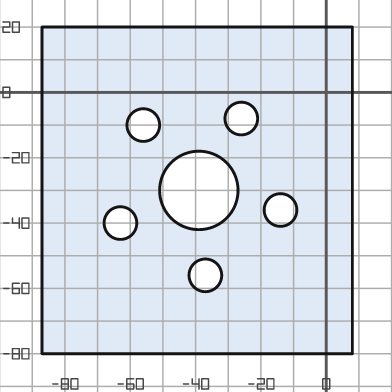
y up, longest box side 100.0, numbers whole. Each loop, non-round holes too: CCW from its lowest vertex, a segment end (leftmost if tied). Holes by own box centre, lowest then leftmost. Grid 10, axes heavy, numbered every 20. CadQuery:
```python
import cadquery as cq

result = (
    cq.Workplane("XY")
    .moveTo(-87.0, -80.0)
    .lineTo(8.0, -80.0)
    .lineTo(8.0, 20.0)
    .lineTo(-87.0, 20.0)
    .close()
    .moveTo(-37.0, -56.0)
    .circle(5.0)
    .moveTo(-63.0, -40.0)
    .circle(5.0)
    .moveTo(-14.0, -36.0)
    .circle(5.0)
    .moveTo(-39.0, -30.0)
    .circle(12.0)
    .moveTo(-56.0, -10.0)
    .circle(5.0)
    .moveTo(-26.0, -8.0)
    .circle(5.0)
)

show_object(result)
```